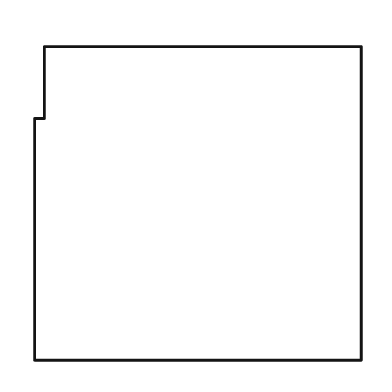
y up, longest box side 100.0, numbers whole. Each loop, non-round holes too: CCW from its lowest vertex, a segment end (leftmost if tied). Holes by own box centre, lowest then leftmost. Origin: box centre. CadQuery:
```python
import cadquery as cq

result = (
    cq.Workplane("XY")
    .moveTo(-50.0, -48.0)
    .lineTo(50.0, -48.0)
    .lineTo(50.0, 48.0)
    .lineTo(-47.0, 48.0)
    .lineTo(-47.0, 26.0)
    .lineTo(-50.0, 26.0)
    .close()
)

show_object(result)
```